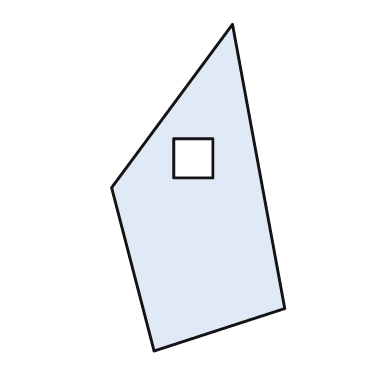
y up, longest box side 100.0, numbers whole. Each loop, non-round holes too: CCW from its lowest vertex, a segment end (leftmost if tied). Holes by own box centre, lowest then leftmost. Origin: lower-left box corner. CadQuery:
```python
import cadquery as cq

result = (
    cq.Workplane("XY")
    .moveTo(13.0, 0.0)
    .lineTo(53.0, 13.0)
    .lineTo(37.0, 100.0)
    .lineTo(0.0, 50.0)
    .close()
    .moveTo(19.0, 53.0)
    .lineTo(31.0, 53.0)
    .lineTo(31.0, 65.0)
    .lineTo(19.0, 65.0)
    .close()
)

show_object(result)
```